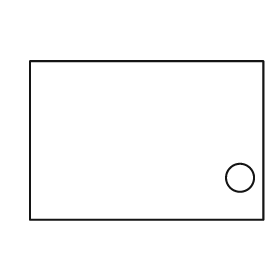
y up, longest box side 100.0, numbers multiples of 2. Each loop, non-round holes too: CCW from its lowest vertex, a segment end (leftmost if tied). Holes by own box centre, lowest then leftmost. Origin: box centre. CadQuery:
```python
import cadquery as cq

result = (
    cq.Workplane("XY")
    .moveTo(-50.0, -34.0)
    .lineTo(50.0, -34.0)
    .lineTo(50.0, 34.0)
    .lineTo(-50.0, 34.0)
    .close()
    .moveTo(40.0, -16.0)
    .circle(6.0)
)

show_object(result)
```